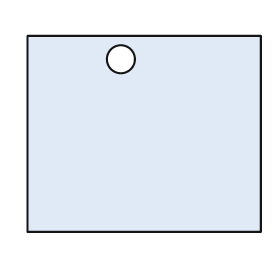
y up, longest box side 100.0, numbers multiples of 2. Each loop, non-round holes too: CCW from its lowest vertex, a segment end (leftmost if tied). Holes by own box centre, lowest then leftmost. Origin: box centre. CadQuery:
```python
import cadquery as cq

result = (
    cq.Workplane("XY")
    .moveTo(-50.0, -42.0)
    .lineTo(50.0, -42.0)
    .lineTo(50.0, 42.0)
    .lineTo(-50.0, 42.0)
    .close()
    .moveTo(-10.0, 32.0)
    .circle(6.0)
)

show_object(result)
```